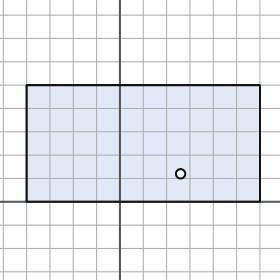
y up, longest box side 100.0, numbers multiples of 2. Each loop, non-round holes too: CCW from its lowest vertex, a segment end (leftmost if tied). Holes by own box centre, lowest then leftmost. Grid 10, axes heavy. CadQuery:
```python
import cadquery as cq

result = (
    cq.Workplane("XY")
    .moveTo(-40.0, 0.0)
    .lineTo(60.0, 0.0)
    .lineTo(60.0, 50.0)
    .lineTo(-40.0, 50.0)
    .close()
    .moveTo(26.0, 12.0)
    .circle(2.0)
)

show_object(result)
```